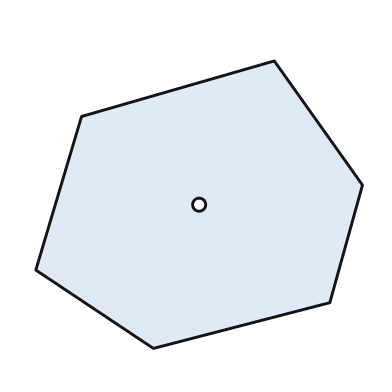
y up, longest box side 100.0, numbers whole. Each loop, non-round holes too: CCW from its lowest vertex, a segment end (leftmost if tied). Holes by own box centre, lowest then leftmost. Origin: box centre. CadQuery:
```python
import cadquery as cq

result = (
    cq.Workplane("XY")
    .moveTo(-14.0, -44.0)
    .lineTo(40.0, -30.0)
    .lineTo(50.0, 6.0)
    .lineTo(23.0, 44.0)
    .lineTo(-36.0, 27.0)
    .lineTo(-50.0, -20.0)
    .close()
    .moveTo(0.0, 0.0)
    .circle(2.0)
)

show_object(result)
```